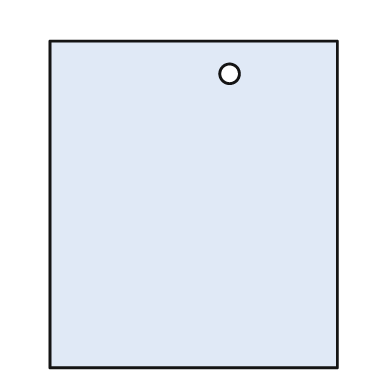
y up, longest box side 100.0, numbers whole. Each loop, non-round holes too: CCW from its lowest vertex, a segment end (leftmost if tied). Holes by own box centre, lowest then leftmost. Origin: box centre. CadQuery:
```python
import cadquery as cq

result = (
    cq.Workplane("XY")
    .moveTo(-44.0, -50.0)
    .lineTo(44.0, -50.0)
    .lineTo(44.0, 50.0)
    .lineTo(-44.0, 50.0)
    .close()
    .moveTo(11.0, 40.0)
    .circle(3.0)
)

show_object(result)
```